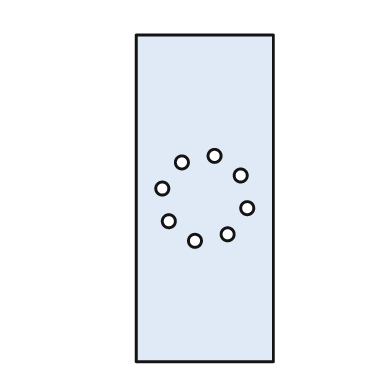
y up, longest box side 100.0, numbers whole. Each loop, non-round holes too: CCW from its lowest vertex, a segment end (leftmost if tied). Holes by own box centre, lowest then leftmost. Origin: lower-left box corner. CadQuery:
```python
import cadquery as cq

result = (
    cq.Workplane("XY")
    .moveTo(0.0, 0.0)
    .lineTo(42.0, 0.0)
    .lineTo(42.0, 100.0)
    .lineTo(0.0, 100.0)
    .close()
    .moveTo(18.0, 37.0)
    .circle(2.0)
    .moveTo(28.0, 39.0)
    .circle(2.0)
    .moveTo(10.0, 43.0)
    .circle(2.0)
    .moveTo(34.0, 47.0)
    .circle(2.0)
    .moveTo(8.0, 53.0)
    .circle(2.0)
    .moveTo(32.0, 57.0)
    .circle(2.0)
    .moveTo(14.0, 61.0)
    .circle(2.0)
    .moveTo(24.0, 63.0)
    .circle(2.0)
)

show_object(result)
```